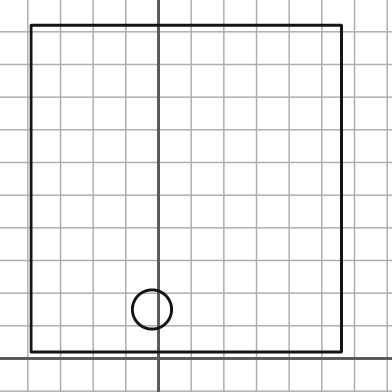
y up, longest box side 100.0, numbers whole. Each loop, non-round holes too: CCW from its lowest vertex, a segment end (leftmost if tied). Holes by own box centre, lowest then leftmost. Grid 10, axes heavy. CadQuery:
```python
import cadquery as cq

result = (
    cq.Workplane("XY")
    .moveTo(-39.0, 2.0)
    .lineTo(56.0, 2.0)
    .lineTo(56.0, 102.0)
    .lineTo(-39.0, 102.0)
    .close()
    .moveTo(-2.0, 15.0)
    .circle(6.0)
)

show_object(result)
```